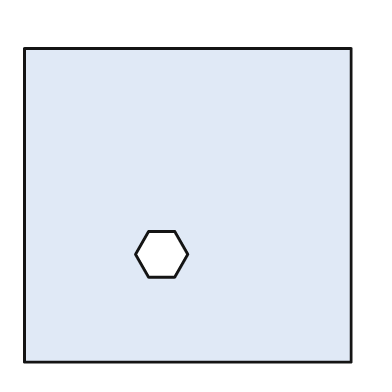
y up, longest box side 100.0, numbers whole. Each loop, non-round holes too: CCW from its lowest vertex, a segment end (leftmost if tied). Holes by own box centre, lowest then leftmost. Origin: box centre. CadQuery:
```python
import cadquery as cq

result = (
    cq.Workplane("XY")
    .moveTo(-50.0, -48.0)
    .lineTo(50.0, -48.0)
    .lineTo(50.0, 48.0)
    .lineTo(-50.0, 48.0)
    .close()
    .moveTo(-12.0, -22.0)
    .lineTo(-4.0, -22.0)
    .lineTo(0.0, -15.0)
    .lineTo(-4.0, -8.0)
    .lineTo(-12.0, -8.0)
    .lineTo(-16.0, -15.0)
    .close()
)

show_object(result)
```